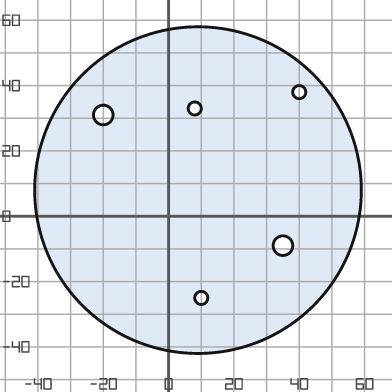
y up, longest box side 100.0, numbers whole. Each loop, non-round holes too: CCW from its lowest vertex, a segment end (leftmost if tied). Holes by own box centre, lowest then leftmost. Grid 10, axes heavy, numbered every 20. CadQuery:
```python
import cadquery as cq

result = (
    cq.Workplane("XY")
    .moveTo(9.0, 8.0)
    .circle(50.0)
    .moveTo(10.0, -25.0)
    .circle(2.0)
    .moveTo(35.0, -9.0)
    .circle(3.0)
    .moveTo(-20.0, 31.0)
    .circle(3.0)
    .moveTo(8.0, 33.0)
    .circle(2.0)
    .moveTo(40.0, 38.0)
    .circle(2.0)
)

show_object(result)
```